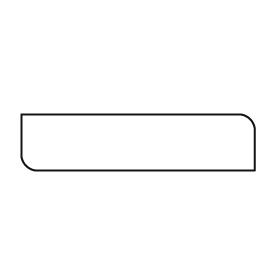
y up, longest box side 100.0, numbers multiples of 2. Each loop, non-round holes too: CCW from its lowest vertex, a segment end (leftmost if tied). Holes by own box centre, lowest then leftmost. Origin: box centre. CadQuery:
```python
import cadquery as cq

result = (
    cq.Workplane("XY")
    .moveTo(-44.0, -12.0)
    .lineTo(50.0, -12.0)
    .lineTo(50.0, 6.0)
    .threePointArc((48.0, 10.0), (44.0, 12.0))
    .lineTo(-50.0, 12.0)
    .lineTo(-50.0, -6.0)
    .threePointArc((-48.0, -10.0), (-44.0, -12.0))
    .close()
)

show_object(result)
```